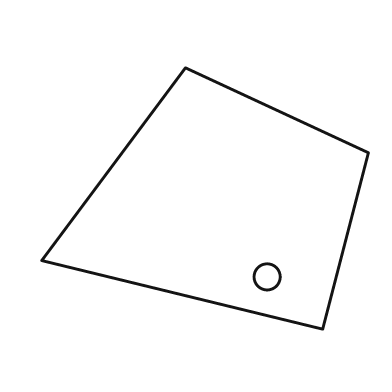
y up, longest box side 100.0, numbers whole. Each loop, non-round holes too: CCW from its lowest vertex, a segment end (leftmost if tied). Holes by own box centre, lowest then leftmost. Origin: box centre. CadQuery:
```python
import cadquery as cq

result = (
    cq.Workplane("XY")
    .moveTo(36.0, -40.0)
    .lineTo(50.0, 14.0)
    .lineTo(-6.0, 40.0)
    .lineTo(-50.0, -19.0)
    .close()
    .moveTo(19.0, -24.0)
    .circle(4.0)
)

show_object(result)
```